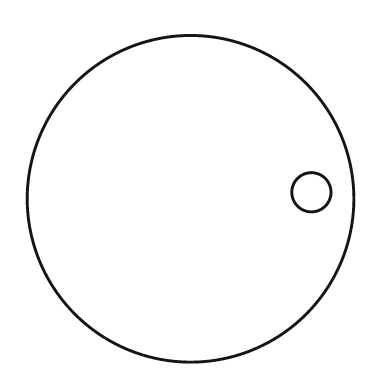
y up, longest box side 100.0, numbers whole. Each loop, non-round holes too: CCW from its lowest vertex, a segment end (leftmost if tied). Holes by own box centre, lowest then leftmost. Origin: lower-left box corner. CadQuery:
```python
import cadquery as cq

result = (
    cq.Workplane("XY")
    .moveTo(50.0, 50.0)
    .circle(50.0)
    .moveTo(87.0, 52.0)
    .circle(6.0)
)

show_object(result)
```